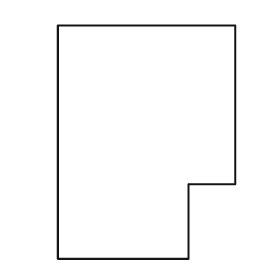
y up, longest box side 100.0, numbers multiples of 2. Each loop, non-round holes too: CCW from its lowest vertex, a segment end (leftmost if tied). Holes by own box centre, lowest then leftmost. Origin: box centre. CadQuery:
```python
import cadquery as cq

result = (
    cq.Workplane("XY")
    .moveTo(-38.0, -50.0)
    .lineTo(18.0, -50.0)
    .lineTo(18.0, -18.0)
    .lineTo(38.0, -18.0)
    .lineTo(38.0, 50.0)
    .lineTo(-38.0, 50.0)
    .close()
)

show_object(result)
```